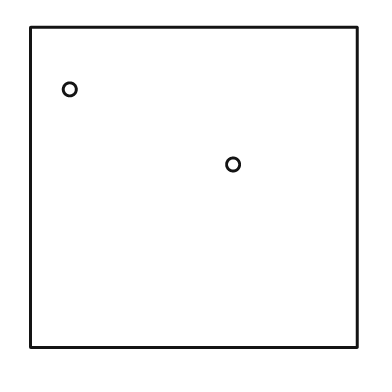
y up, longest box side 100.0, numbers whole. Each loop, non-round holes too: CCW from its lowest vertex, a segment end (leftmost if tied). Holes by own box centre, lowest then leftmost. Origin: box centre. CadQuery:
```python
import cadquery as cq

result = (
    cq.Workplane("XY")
    .moveTo(-50.0, -49.0)
    .lineTo(50.0, -49.0)
    .lineTo(50.0, 49.0)
    .lineTo(-50.0, 49.0)
    .close()
    .moveTo(12.0, 7.0)
    .circle(2.0)
    .moveTo(-38.0, 30.0)
    .circle(2.0)
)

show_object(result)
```